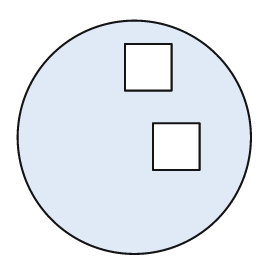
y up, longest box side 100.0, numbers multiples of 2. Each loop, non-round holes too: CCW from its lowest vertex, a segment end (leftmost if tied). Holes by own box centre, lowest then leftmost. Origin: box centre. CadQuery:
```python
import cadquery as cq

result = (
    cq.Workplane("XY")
    .moveTo(0.0, 0.0)
    .circle(50.0)
    .moveTo(8.0, -14.0)
    .lineTo(28.0, -14.0)
    .lineTo(28.0, 6.0)
    .lineTo(8.0, 6.0)
    .close()
    .moveTo(-4.0, 20.0)
    .lineTo(16.0, 20.0)
    .lineTo(16.0, 40.0)
    .lineTo(-4.0, 40.0)
    .close()
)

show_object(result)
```